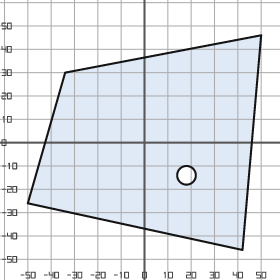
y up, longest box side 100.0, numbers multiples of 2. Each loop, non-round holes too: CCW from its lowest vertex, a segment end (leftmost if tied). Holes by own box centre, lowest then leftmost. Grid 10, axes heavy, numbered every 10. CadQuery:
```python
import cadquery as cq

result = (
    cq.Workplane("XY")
    .moveTo(42.0, -46.0)
    .lineTo(50.0, 46.0)
    .lineTo(-34.0, 30.0)
    .lineTo(-50.0, -26.0)
    .close()
    .moveTo(18.0, -14.0)
    .circle(4.0)
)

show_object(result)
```